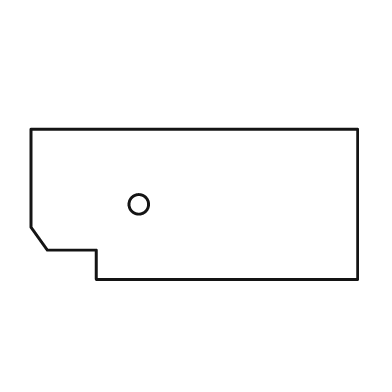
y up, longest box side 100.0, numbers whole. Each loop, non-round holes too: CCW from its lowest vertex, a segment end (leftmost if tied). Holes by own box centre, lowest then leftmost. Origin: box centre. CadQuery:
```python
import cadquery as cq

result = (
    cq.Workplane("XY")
    .moveTo(-30.0, -23.0)
    .lineTo(50.0, -23.0)
    .lineTo(50.0, 23.0)
    .lineTo(-50.0, 23.0)
    .lineTo(-50.0, -7.0)
    .lineTo(-45.0, -14.0)
    .lineTo(-30.0, -14.0)
    .close()
    .moveTo(-17.0, 0.0)
    .circle(3.0)
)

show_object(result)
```